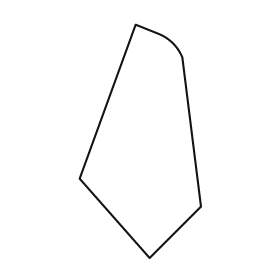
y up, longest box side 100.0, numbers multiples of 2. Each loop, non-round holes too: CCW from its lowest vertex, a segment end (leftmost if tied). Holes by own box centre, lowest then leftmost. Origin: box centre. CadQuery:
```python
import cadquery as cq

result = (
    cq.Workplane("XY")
    .moveTo(4.0, -50.0)
    .lineTo(26.0, -28.0)
    .lineTo(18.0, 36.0)
    .threePointArc((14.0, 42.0), (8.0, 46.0))
    .lineTo(-2.0, 50.0)
    .lineTo(-26.0, -16.0)
    .close()
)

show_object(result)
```